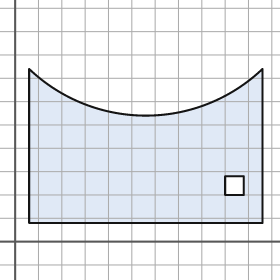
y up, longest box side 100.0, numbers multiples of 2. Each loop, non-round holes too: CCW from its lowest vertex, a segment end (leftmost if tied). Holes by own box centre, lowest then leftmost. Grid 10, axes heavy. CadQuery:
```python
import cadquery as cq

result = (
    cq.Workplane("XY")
    .moveTo(6.0, 8.0)
    .lineTo(106.0, 8.0)
    .lineTo(106.0, 74.0)
    .threePointArc((56.0, 54.0), (6.0, 74.0))
    .close()
    .moveTo(90.0, 20.0)
    .lineTo(98.0, 20.0)
    .lineTo(98.0, 28.0)
    .lineTo(90.0, 28.0)
    .close()
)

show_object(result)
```